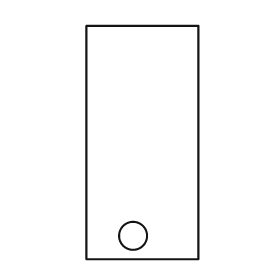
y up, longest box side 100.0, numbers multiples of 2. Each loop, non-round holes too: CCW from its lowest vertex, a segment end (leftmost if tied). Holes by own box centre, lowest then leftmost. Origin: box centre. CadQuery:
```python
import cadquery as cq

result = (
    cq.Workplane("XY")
    .moveTo(-24.0, -50.0)
    .lineTo(24.0, -50.0)
    .lineTo(24.0, 50.0)
    .lineTo(-24.0, 50.0)
    .close()
    .moveTo(-4.0, -40.0)
    .circle(6.0)
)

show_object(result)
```